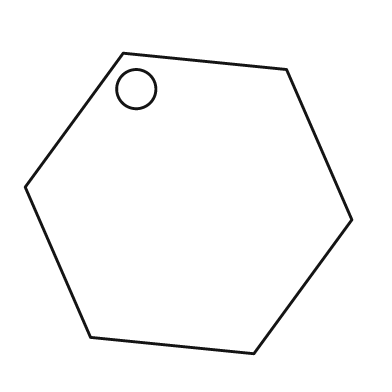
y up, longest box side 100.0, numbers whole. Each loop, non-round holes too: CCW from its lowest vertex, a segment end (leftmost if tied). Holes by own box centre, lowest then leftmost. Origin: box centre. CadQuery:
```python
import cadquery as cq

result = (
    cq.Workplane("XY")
    .moveTo(20.0, -46.0)
    .lineTo(50.0, -5.0)
    .lineTo(30.0, 41.0)
    .lineTo(-20.0, 46.0)
    .lineTo(-50.0, 5.0)
    .lineTo(-30.0, -41.0)
    .close()
    .moveTo(-16.0, 35.0)
    .circle(6.0)
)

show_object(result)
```